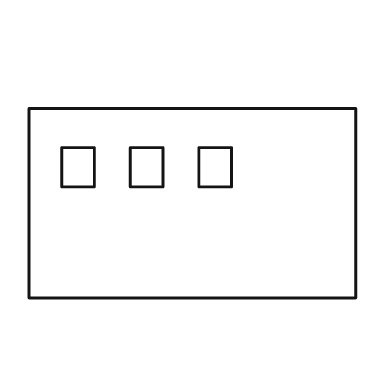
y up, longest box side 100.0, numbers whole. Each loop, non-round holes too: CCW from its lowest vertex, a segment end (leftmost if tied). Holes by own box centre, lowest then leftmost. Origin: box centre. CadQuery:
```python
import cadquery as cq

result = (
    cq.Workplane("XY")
    .moveTo(-50.0, -29.0)
    .lineTo(50.0, -29.0)
    .lineTo(50.0, 29.0)
    .lineTo(-50.0, 29.0)
    .close()
    .moveTo(-40.0, 5.0)
    .lineTo(-30.0, 5.0)
    .lineTo(-30.0, 17.0)
    .lineTo(-40.0, 17.0)
    .close()
    .moveTo(-19.0, 5.0)
    .lineTo(-9.0, 5.0)
    .lineTo(-9.0, 17.0)
    .lineTo(-19.0, 17.0)
    .close()
    .moveTo(2.0, 5.0)
    .lineTo(12.0, 5.0)
    .lineTo(12.0, 17.0)
    .lineTo(2.0, 17.0)
    .close()
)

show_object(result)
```